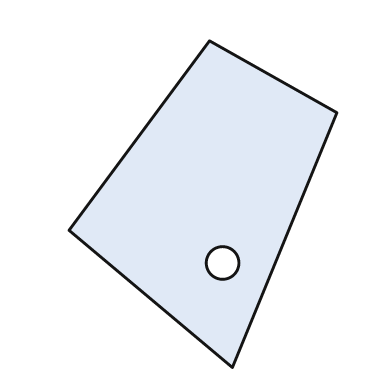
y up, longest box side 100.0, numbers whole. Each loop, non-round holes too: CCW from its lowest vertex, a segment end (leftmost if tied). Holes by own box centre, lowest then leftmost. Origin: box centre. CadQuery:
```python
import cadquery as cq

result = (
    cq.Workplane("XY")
    .moveTo(9.0, -50.0)
    .lineTo(41.0, 28.0)
    .lineTo(2.0, 50.0)
    .lineTo(-41.0, -8.0)
    .close()
    .moveTo(6.0, -18.0)
    .circle(5.0)
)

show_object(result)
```